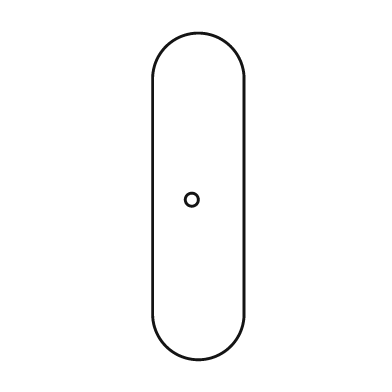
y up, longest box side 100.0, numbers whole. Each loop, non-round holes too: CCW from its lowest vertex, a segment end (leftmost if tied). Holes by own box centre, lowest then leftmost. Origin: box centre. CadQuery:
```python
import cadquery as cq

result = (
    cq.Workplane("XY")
    .moveTo(-14.0, -36.0)
    .threePointArc((0.0, -50.0), (14.0, -36.0))
    .lineTo(14.0, 36.0)
    .threePointArc((0.0, 50.0), (-14.0, 36.0))
    .close()
    .moveTo(-2.0, -1.0)
    .circle(2.0)
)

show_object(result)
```